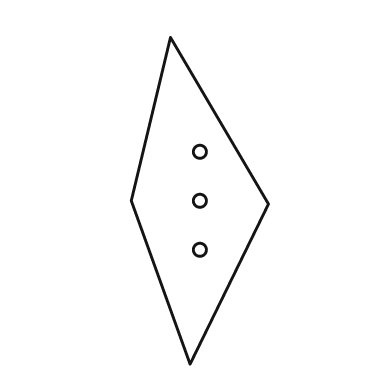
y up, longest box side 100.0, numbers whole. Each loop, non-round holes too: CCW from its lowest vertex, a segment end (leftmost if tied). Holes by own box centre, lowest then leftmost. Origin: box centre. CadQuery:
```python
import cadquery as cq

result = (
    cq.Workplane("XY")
    .moveTo(-3.0, -50.0)
    .lineTo(21.0, -1.0)
    .lineTo(-9.0, 50.0)
    .lineTo(-21.0, 0.0)
    .close()
    .moveTo(0.0, -15.0)
    .circle(2.0)
    .moveTo(0.0, 0.0)
    .circle(2.0)
    .moveTo(0.0, 15.0)
    .circle(2.0)
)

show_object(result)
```